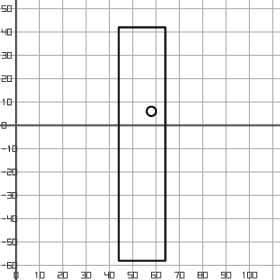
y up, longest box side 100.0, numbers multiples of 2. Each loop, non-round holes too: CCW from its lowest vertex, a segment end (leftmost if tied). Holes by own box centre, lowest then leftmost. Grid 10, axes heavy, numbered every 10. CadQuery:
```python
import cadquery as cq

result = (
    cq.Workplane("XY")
    .moveTo(44.0, -58.0)
    .lineTo(64.0, -58.0)
    .lineTo(64.0, 42.0)
    .lineTo(44.0, 42.0)
    .close()
    .moveTo(58.0, 6.0)
    .circle(2.0)
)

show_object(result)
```